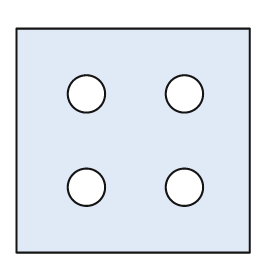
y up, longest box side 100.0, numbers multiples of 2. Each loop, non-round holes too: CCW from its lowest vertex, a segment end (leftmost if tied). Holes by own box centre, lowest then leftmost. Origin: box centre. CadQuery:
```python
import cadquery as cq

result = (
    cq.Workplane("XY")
    .moveTo(-50.0, -48.0)
    .lineTo(50.0, -48.0)
    .lineTo(50.0, 48.0)
    .lineTo(-50.0, 48.0)
    .close()
    .moveTo(-20.0, -20.0)
    .circle(8.0)
    .moveTo(22.0, -20.0)
    .circle(8.0)
    .moveTo(-20.0, 20.0)
    .circle(8.0)
    .moveTo(22.0, 20.0)
    .circle(8.0)
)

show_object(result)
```